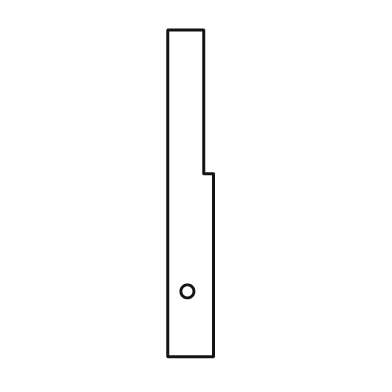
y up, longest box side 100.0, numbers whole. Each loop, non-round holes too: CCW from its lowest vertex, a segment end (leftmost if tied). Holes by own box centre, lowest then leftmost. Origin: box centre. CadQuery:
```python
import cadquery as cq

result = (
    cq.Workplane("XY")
    .moveTo(-7.0, -50.0)
    .lineTo(7.0, -50.0)
    .lineTo(7.0, 6.0)
    .lineTo(4.0, 6.0)
    .lineTo(4.0, 50.0)
    .lineTo(-7.0, 50.0)
    .close()
    .moveTo(-1.0, -30.0)
    .circle(2.0)
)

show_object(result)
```